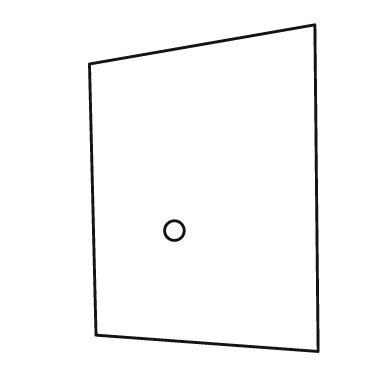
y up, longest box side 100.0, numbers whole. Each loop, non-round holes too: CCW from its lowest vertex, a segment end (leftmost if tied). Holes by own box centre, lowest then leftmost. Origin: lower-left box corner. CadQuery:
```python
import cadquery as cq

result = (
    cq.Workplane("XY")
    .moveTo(70.0, 0.0)
    .lineTo(69.0, 100.0)
    .lineTo(0.0, 88.0)
    .lineTo(2.0, 5.0)
    .close()
    .moveTo(26.0, 37.0)
    .circle(3.0)
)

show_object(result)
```